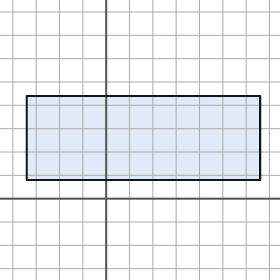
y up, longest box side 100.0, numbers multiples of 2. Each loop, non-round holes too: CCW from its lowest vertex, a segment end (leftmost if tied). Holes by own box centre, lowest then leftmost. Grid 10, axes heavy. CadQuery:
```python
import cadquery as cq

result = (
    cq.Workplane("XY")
    .moveTo(-34.0, 8.0)
    .lineTo(66.0, 8.0)
    .lineTo(66.0, 44.0)
    .lineTo(-34.0, 44.0)
    .close()
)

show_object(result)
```